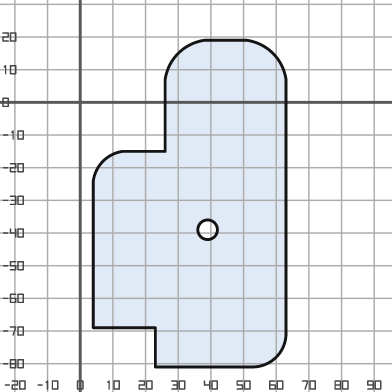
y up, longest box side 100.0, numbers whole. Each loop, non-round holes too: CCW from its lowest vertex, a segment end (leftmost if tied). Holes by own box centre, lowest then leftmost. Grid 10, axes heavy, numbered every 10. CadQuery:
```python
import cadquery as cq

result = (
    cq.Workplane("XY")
    .moveTo(23.0, -81.0)
    .lineTo(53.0, -81.0)
    .threePointArc((60.0, -78.0), (63.0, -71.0))
    .lineTo(63.0, 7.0)
    .threePointArc((59.0, 15.0), (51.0, 19.0))
    .lineTo(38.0, 19.0)
    .threePointArc((30.0, 15.0), (26.0, 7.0))
    .lineTo(26.0, -15.0)
    .lineTo(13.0, -15.0)
    .threePointArc((7.0, -18.0), (4.0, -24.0))
    .lineTo(4.0, -69.0)
    .lineTo(23.0, -69.0)
    .close()
    .moveTo(39.0, -39.0)
    .circle(3.0)
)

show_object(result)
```